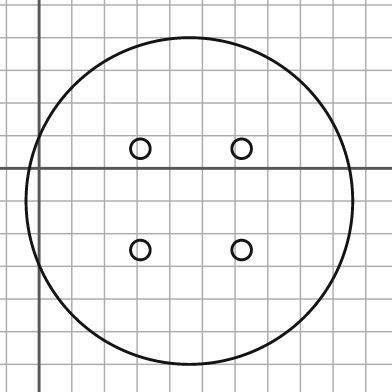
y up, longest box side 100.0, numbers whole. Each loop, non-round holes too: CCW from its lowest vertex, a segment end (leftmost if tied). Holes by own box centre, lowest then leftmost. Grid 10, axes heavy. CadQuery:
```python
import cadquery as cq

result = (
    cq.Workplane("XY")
    .moveTo(46.0, -10.0)
    .circle(50.0)
    .moveTo(31.0, -25.0)
    .circle(3.0)
    .moveTo(62.0, -25.0)
    .circle(3.0)
    .moveTo(31.0, 6.0)
    .circle(3.0)
    .moveTo(62.0, 6.0)
    .circle(3.0)
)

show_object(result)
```